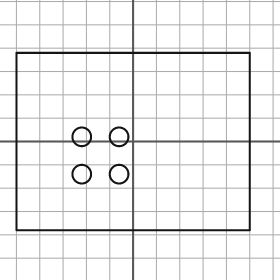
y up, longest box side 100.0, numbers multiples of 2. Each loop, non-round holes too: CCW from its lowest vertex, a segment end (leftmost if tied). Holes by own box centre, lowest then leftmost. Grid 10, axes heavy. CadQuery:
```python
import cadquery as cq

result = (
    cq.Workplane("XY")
    .moveTo(-50.0, -38.0)
    .lineTo(50.0, -38.0)
    .lineTo(50.0, 38.0)
    .lineTo(-50.0, 38.0)
    .close()
    .moveTo(-22.0, -14.0)
    .circle(4.0)
    .moveTo(-6.0, -14.0)
    .circle(4.0)
    .moveTo(-22.0, 2.0)
    .circle(4.0)
    .moveTo(-6.0, 2.0)
    .circle(4.0)
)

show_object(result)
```